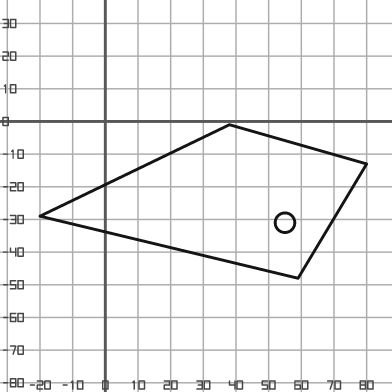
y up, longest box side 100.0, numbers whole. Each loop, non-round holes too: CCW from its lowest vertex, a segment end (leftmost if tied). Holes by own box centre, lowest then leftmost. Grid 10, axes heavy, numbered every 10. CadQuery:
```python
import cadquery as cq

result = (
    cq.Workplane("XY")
    .moveTo(59.0, -48.0)
    .lineTo(80.0, -13.0)
    .lineTo(38.0, -1.0)
    .lineTo(-20.0, -29.0)
    .close()
    .moveTo(55.0, -31.0)
    .circle(3.0)
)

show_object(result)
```